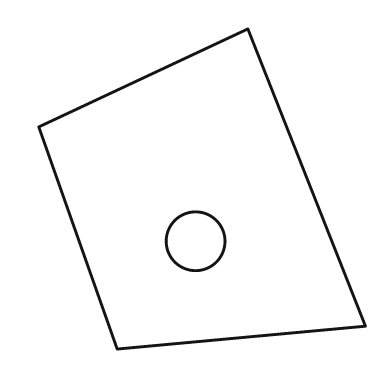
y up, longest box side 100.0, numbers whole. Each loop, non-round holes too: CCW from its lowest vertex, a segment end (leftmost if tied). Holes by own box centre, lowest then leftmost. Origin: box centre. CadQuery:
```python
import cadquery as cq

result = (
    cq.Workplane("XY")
    .moveTo(-26.0, -49.0)
    .lineTo(50.0, -42.0)
    .lineTo(14.0, 49.0)
    .lineTo(-50.0, 19.0)
    .close()
    .moveTo(-2.0, -16.0)
    .circle(9.0)
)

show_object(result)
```